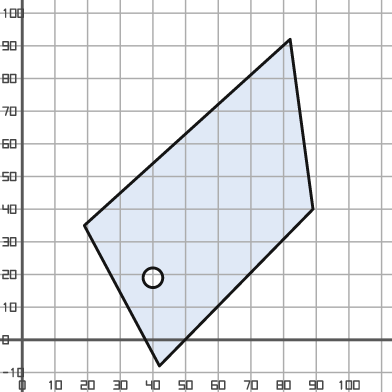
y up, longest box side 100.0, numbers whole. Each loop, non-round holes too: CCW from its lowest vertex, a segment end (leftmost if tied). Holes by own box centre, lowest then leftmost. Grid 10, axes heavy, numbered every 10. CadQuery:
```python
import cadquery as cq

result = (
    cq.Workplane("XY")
    .moveTo(42.0, -8.0)
    .lineTo(89.0, 40.0)
    .lineTo(82.0, 92.0)
    .lineTo(19.0, 35.0)
    .close()
    .moveTo(40.0, 19.0)
    .circle(3.0)
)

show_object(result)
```